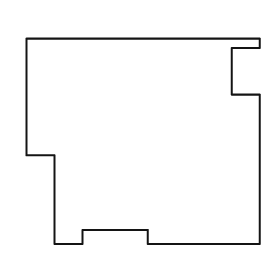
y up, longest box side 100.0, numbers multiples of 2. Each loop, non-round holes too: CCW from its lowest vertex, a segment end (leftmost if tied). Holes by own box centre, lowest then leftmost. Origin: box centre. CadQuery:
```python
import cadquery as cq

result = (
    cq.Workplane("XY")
    .moveTo(-38.0, -44.0)
    .lineTo(-26.0, -44.0)
    .lineTo(-26.0, -38.0)
    .lineTo(2.0, -38.0)
    .lineTo(2.0, -44.0)
    .lineTo(50.0, -44.0)
    .lineTo(50.0, 20.0)
    .lineTo(38.0, 20.0)
    .lineTo(38.0, 40.0)
    .lineTo(50.0, 40.0)
    .lineTo(50.0, 44.0)
    .lineTo(-50.0, 44.0)
    .lineTo(-50.0, -6.0)
    .lineTo(-38.0, -6.0)
    .close()
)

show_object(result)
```